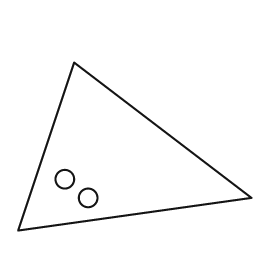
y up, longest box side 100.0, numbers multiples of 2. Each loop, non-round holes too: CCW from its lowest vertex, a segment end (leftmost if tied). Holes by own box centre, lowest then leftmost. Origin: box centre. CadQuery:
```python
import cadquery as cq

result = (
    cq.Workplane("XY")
    .moveTo(-50.0, -36.0)
    .lineTo(50.0, -22.0)
    .lineTo(-26.0, 36.0)
    .close()
    .moveTo(-20.0, -22.0)
    .circle(4.0)
    .moveTo(-30.0, -14.0)
    .circle(4.0)
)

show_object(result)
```